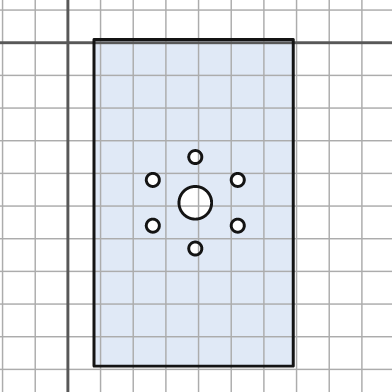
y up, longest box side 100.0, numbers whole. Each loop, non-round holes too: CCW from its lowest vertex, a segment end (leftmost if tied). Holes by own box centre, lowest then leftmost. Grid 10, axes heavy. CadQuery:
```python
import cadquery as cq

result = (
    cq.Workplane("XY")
    .moveTo(8.0, -99.0)
    .lineTo(69.0, -99.0)
    .lineTo(69.0, 1.0)
    .lineTo(8.0, 1.0)
    .close()
    .moveTo(39.0, -63.0)
    .circle(2.0)
    .moveTo(26.0, -56.0)
    .circle(2.0)
    .moveTo(52.0, -56.0)
    .circle(2.0)
    .moveTo(39.0, -49.0)
    .circle(5.0)
    .moveTo(26.0, -42.0)
    .circle(2.0)
    .moveTo(52.0, -42.0)
    .circle(2.0)
    .moveTo(39.0, -35.0)
    .circle(2.0)
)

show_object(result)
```